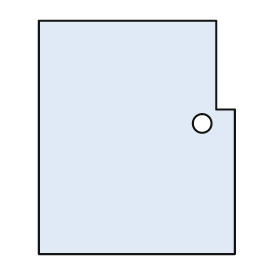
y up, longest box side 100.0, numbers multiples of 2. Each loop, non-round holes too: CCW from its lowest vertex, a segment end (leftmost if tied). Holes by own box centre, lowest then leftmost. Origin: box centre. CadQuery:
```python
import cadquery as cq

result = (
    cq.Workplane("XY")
    .moveTo(-42.0, -50.0)
    .lineTo(42.0, -50.0)
    .lineTo(42.0, 12.0)
    .lineTo(34.0, 12.0)
    .lineTo(34.0, 50.0)
    .lineTo(-42.0, 50.0)
    .close()
    .moveTo(28.0, 6.0)
    .circle(4.0)
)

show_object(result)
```